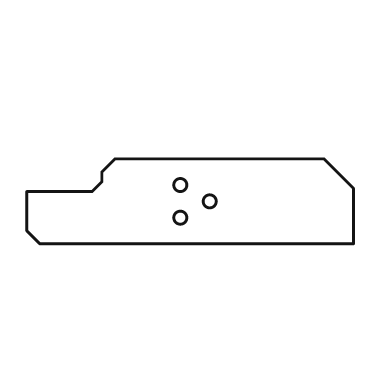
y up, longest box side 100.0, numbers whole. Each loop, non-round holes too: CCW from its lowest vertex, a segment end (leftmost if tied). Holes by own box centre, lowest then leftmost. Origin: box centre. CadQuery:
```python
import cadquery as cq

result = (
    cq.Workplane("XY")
    .moveTo(-46.0, -13.0)
    .lineTo(50.0, -13.0)
    .lineTo(50.0, 4.0)
    .lineTo(41.0, 13.0)
    .lineTo(-23.0, 13.0)
    .lineTo(-27.0, 9.0)
    .lineTo(-27.0, 6.0)
    .lineTo(-30.0, 3.0)
    .lineTo(-50.0, 3.0)
    .lineTo(-50.0, -9.0)
    .close()
    .moveTo(-3.0, -5.0)
    .circle(2.0)
    .moveTo(6.0, 0.0)
    .circle(2.0)
    .moveTo(-3.0, 5.0)
    .circle(2.0)
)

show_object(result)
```